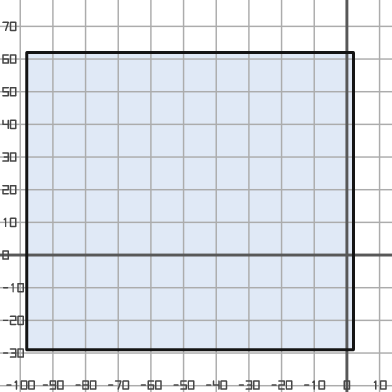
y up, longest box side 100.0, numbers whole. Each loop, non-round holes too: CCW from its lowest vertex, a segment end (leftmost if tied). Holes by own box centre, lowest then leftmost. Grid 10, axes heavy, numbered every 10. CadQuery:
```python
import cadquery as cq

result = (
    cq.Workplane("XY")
    .moveTo(-98.0, -29.0)
    .lineTo(2.0, -29.0)
    .lineTo(2.0, 62.0)
    .lineTo(-98.0, 62.0)
    .close()
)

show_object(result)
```